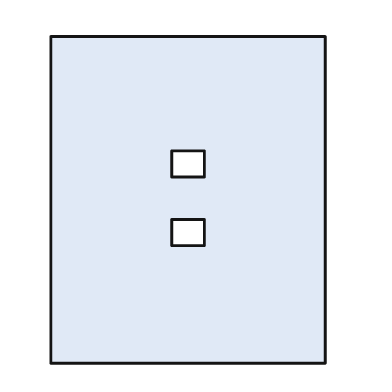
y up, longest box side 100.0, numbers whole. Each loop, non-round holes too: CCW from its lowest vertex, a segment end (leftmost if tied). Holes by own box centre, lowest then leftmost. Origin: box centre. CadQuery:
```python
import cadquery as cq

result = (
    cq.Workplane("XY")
    .moveTo(-42.0, -50.0)
    .lineTo(42.0, -50.0)
    .lineTo(42.0, 50.0)
    .lineTo(-42.0, 50.0)
    .close()
    .moveTo(-5.0, -14.0)
    .lineTo(5.0, -14.0)
    .lineTo(5.0, -6.0)
    .lineTo(-5.0, -6.0)
    .close()
    .moveTo(-5.0, 7.0)
    .lineTo(5.0, 7.0)
    .lineTo(5.0, 15.0)
    .lineTo(-5.0, 15.0)
    .close()
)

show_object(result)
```